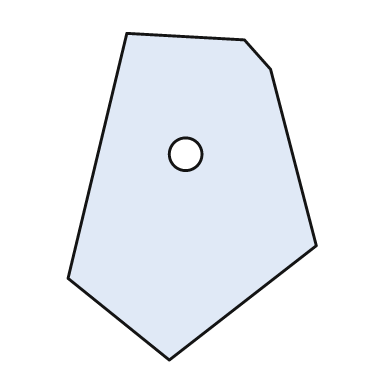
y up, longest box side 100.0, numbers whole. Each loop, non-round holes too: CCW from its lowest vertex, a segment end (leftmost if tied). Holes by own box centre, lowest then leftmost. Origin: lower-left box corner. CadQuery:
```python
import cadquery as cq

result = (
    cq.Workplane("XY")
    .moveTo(31.0, 0.0)
    .lineTo(76.0, 35.0)
    .lineTo(62.0, 89.0)
    .lineTo(54.0, 98.0)
    .lineTo(18.0, 100.0)
    .lineTo(0.0, 25.0)
    .close()
    .moveTo(36.0, 63.0)
    .circle(5.0)
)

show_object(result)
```